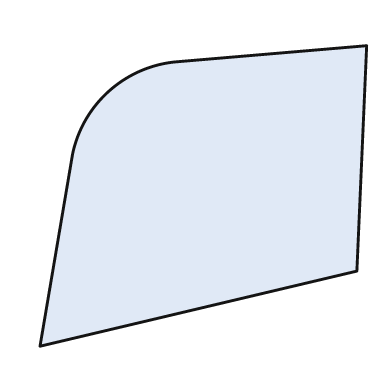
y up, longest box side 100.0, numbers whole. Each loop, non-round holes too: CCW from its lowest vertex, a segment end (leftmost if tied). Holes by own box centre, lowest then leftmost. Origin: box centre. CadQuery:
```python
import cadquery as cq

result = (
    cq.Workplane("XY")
    .moveTo(-50.0, -46.0)
    .lineTo(47.0, -23.0)
    .lineTo(50.0, 46.0)
    .lineTo(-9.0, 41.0)
    .threePointArc((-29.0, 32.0), (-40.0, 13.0))
    .close()
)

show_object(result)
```